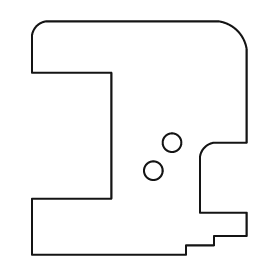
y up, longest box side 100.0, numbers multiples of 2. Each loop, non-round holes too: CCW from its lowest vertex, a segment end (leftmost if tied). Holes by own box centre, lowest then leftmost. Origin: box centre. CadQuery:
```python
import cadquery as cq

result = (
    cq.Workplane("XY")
    .moveTo(-46.0, -50.0)
    .lineTo(20.0, -50.0)
    .lineTo(20.0, -46.0)
    .lineTo(32.0, -46.0)
    .lineTo(32.0, -42.0)
    .lineTo(46.0, -42.0)
    .lineTo(46.0, -32.0)
    .lineTo(26.0, -32.0)
    .lineTo(26.0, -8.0)
    .threePointArc((28.0, -4.0), (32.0, -2.0))
    .lineTo(46.0, -2.0)
    .lineTo(46.0, 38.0)
    .threePointArc((42.0, 46.0), (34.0, 50.0))
    .lineTo(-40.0, 50.0)
    .threePointArc((-44.0, 48.0), (-46.0, 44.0))
    .lineTo(-46.0, 28.0)
    .lineTo(-12.0, 28.0)
    .lineTo(-12.0, -26.0)
    .lineTo(-46.0, -26.0)
    .close()
    .moveTo(6.0, -14.0)
    .circle(4.0)
    .moveTo(14.0, -2.0)
    .circle(4.0)
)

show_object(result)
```